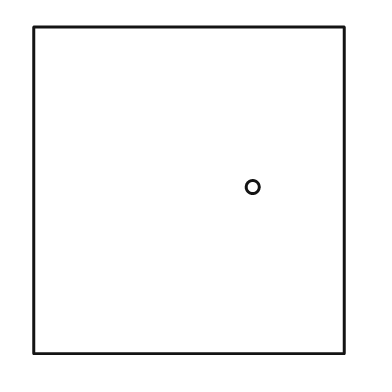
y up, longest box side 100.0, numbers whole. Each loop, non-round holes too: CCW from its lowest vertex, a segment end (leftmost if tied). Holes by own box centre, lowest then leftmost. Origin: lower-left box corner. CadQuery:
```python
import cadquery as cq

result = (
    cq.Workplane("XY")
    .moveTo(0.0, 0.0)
    .lineTo(95.0, 0.0)
    .lineTo(95.0, 100.0)
    .lineTo(0.0, 100.0)
    .close()
    .moveTo(67.0, 51.0)
    .circle(2.0)
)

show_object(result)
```